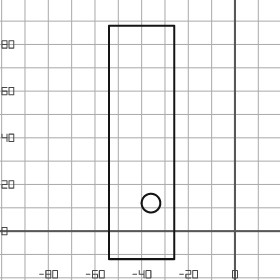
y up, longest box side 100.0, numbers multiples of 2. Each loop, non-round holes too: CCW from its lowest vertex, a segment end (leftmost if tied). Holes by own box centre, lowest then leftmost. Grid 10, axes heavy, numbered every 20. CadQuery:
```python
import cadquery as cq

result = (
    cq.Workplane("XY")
    .moveTo(-54.0, -12.0)
    .lineTo(-26.0, -12.0)
    .lineTo(-26.0, 88.0)
    .lineTo(-54.0, 88.0)
    .close()
    .moveTo(-36.0, 12.0)
    .circle(4.0)
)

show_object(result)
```